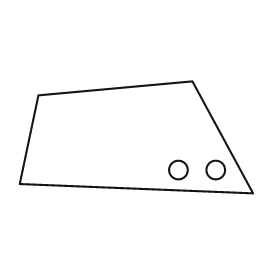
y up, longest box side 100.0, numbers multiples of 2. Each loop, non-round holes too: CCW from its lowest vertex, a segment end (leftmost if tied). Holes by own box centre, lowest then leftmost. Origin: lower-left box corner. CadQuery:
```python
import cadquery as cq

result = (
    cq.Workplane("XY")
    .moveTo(100.0, 0.0)
    .lineTo(74.0, 48.0)
    .lineTo(8.0, 42.0)
    .lineTo(0.0, 4.0)
    .close()
    .moveTo(68.0, 10.0)
    .circle(4.0)
    .moveTo(84.0, 10.0)
    .circle(4.0)
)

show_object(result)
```